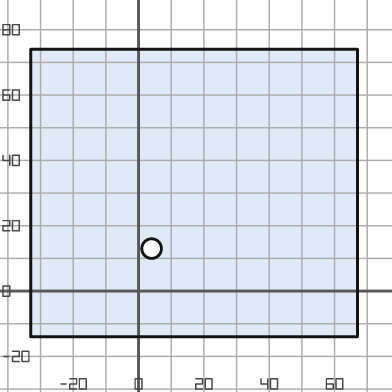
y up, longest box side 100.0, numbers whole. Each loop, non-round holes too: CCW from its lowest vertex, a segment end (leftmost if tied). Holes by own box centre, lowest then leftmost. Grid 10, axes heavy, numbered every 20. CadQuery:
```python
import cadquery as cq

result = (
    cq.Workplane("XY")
    .moveTo(-33.0, -14.0)
    .lineTo(67.0, -14.0)
    .lineTo(67.0, 74.0)
    .lineTo(-33.0, 74.0)
    .close()
    .moveTo(4.0, 13.0)
    .circle(3.0)
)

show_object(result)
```